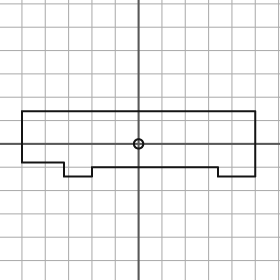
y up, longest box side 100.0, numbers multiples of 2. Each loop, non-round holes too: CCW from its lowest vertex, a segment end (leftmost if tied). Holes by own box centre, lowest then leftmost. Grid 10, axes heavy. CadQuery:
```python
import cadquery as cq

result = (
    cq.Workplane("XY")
    .moveTo(-32.0, -14.0)
    .lineTo(-20.0, -14.0)
    .lineTo(-20.0, -10.0)
    .lineTo(34.0, -10.0)
    .lineTo(34.0, -14.0)
    .lineTo(50.0, -14.0)
    .lineTo(50.0, 14.0)
    .lineTo(-50.0, 14.0)
    .lineTo(-50.0, -8.0)
    .lineTo(-32.0, -8.0)
    .close()
    .moveTo(0.0, 0.0)
    .circle(2.0)
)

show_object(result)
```